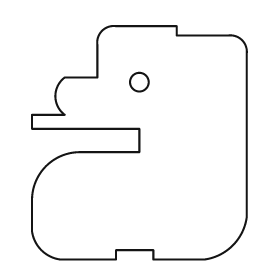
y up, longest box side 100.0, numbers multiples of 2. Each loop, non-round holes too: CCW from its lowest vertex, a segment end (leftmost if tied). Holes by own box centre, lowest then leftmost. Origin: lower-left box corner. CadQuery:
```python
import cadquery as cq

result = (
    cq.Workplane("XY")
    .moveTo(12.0, 0.0)
    .lineTo(36.0, 0.0)
    .lineTo(36.0, 4.0)
    .lineTo(52.0, 4.0)
    .lineTo(52.0, 0.0)
    .lineTo(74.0, 0.0)
    .threePointArc((86.0, 6.0), (92.0, 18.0))
    .lineTo(92.0, 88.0)
    .threePointArc((90.0, 94.0), (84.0, 96.0))
    .lineTo(62.0, 96.0)
    .lineTo(62.0, 100.0)
    .lineTo(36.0, 100.0)
    .threePointArc((30.0, 98.0), (28.0, 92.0))
    .lineTo(28.0, 78.0)
    .lineTo(14.0, 78.0)
    .threePointArc((10.0, 70.0), (14.0, 62.0))
    .lineTo(0.0, 62.0)
    .lineTo(0.0, 56.0)
    .lineTo(46.0, 56.0)
    .lineTo(46.0, 46.0)
    .lineTo(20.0, 46.0)
    .threePointArc((6.0, 40.0), (0.0, 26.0))
    .lineTo(0.0, 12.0)
    .threePointArc((4.0, 4.0), (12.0, 0.0))
    .close()
    .moveTo(46.0, 76.0)
    .circle(4.0)
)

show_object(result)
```